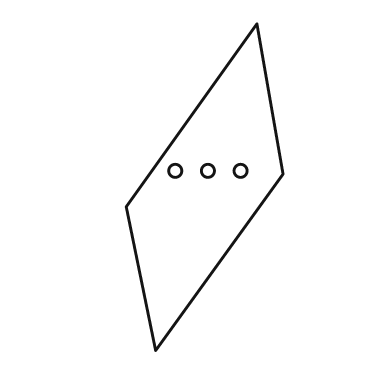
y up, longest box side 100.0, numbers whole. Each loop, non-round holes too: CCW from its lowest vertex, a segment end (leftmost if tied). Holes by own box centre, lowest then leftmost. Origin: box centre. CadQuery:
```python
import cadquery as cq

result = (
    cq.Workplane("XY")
    .moveTo(-15.0, -50.0)
    .lineTo(24.0, 4.0)
    .lineTo(16.0, 50.0)
    .lineTo(-24.0, -6.0)
    .close()
    .moveTo(-9.0, 5.0)
    .circle(2.0)
    .moveTo(1.0, 5.0)
    .circle(2.0)
    .moveTo(11.0, 5.0)
    .circle(2.0)
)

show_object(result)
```